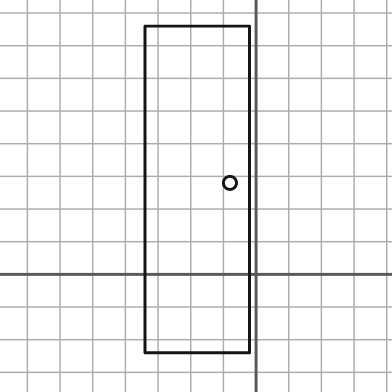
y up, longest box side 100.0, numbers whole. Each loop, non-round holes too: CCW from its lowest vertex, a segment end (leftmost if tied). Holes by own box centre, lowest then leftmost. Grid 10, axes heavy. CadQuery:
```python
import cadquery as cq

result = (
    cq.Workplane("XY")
    .moveTo(-34.0, -24.0)
    .lineTo(-2.0, -24.0)
    .lineTo(-2.0, 76.0)
    .lineTo(-34.0, 76.0)
    .close()
    .moveTo(-8.0, 28.0)
    .circle(2.0)
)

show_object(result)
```